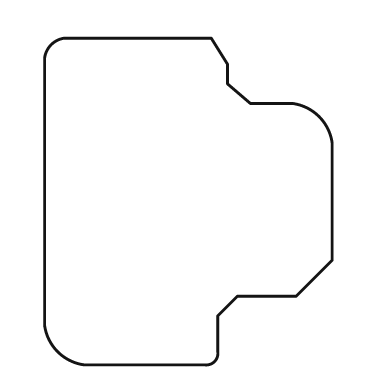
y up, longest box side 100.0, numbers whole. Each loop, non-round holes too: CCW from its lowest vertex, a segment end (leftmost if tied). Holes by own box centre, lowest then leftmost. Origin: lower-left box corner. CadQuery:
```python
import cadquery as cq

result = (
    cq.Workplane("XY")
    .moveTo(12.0, 0.0)
    .lineTo(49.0, 0.0)
    .threePointArc((52.0, 1.0), (53.0, 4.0))
    .lineTo(53.0, 15.0)
    .lineTo(59.0, 21.0)
    .lineTo(77.0, 21.0)
    .lineTo(88.0, 32.0)
    .lineTo(88.0, 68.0)
    .threePointArc((84.0, 76.0), (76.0, 80.0))
    .lineTo(63.0, 80.0)
    .lineTo(56.0, 86.0)
    .lineTo(56.0, 92.0)
    .lineTo(51.0, 100.0)
    .lineTo(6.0, 100.0)
    .threePointArc((2.0, 98.0), (0.0, 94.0))
    .lineTo(0.0, 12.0)
    .threePointArc((4.0, 4.0), (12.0, 0.0))
    .close()
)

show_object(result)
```